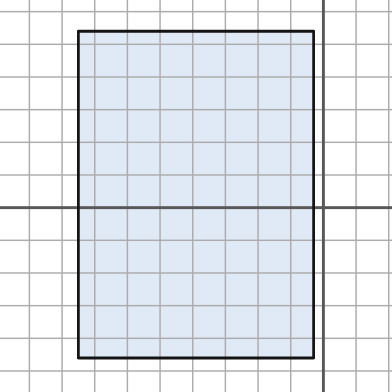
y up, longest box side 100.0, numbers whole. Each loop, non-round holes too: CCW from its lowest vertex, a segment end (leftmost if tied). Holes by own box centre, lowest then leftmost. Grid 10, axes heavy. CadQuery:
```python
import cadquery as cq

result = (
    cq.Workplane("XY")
    .moveTo(-75.0, -46.0)
    .lineTo(-3.0, -46.0)
    .lineTo(-3.0, 54.0)
    .lineTo(-75.0, 54.0)
    .close()
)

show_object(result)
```